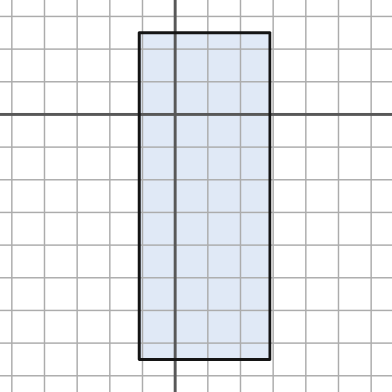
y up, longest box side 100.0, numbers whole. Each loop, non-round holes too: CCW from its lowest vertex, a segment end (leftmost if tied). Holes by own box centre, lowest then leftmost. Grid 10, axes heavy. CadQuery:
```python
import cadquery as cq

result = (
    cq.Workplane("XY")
    .moveTo(-11.0, -75.0)
    .lineTo(29.0, -75.0)
    .lineTo(29.0, 25.0)
    .lineTo(-11.0, 25.0)
    .close()
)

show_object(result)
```